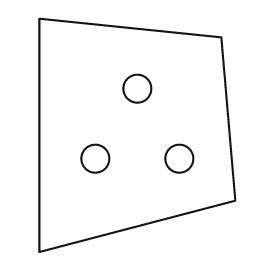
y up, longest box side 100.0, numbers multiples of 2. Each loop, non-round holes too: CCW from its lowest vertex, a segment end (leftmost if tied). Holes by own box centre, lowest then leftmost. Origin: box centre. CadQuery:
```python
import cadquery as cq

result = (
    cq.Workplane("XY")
    .moveTo(-42.0, -50.0)
    .lineTo(42.0, -28.0)
    .lineTo(36.0, 42.0)
    .lineTo(-42.0, 50.0)
    .close()
    .moveTo(-18.0, -10.0)
    .circle(6.0)
    .moveTo(18.0, -10.0)
    .circle(6.0)
    .moveTo(0.0, 20.0)
    .circle(6.0)
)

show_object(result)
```